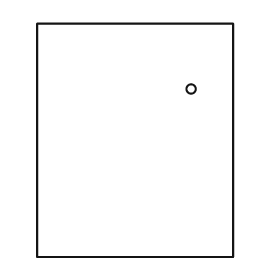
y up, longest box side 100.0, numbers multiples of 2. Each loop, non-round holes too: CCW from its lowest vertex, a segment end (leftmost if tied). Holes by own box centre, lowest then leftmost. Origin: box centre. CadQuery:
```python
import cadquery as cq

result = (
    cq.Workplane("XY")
    .moveTo(-42.0, -50.0)
    .lineTo(42.0, -50.0)
    .lineTo(42.0, 50.0)
    .lineTo(-42.0, 50.0)
    .close()
    .moveTo(24.0, 22.0)
    .circle(2.0)
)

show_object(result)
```